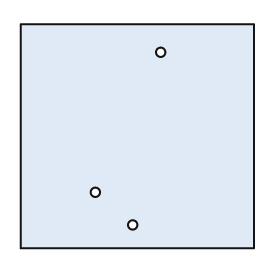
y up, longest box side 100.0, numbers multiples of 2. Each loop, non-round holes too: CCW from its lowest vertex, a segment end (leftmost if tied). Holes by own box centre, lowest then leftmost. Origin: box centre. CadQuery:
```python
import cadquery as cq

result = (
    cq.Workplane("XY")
    .moveTo(-50.0, -48.0)
    .lineTo(50.0, -48.0)
    .lineTo(50.0, 48.0)
    .lineTo(-50.0, 48.0)
    .close()
    .moveTo(-2.0, -38.0)
    .circle(2.0)
    .moveTo(-18.0, -24.0)
    .circle(2.0)
    .moveTo(10.0, 36.0)
    .circle(2.0)
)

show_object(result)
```